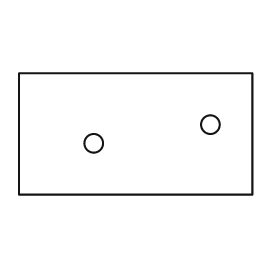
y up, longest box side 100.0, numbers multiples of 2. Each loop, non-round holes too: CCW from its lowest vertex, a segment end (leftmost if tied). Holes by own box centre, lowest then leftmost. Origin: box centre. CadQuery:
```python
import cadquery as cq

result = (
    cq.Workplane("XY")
    .moveTo(-50.0, -26.0)
    .lineTo(50.0, -26.0)
    .lineTo(50.0, 26.0)
    .lineTo(-50.0, 26.0)
    .close()
    .moveTo(-18.0, -4.0)
    .circle(4.0)
    .moveTo(32.0, 4.0)
    .circle(4.0)
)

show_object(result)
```